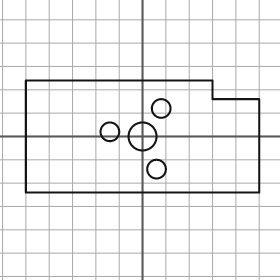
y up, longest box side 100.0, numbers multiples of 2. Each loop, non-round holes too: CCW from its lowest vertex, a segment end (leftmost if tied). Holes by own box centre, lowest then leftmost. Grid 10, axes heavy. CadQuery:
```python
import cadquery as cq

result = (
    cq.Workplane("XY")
    .moveTo(-50.0, -24.0)
    .lineTo(50.0, -24.0)
    .lineTo(50.0, 16.0)
    .lineTo(30.0, 16.0)
    .lineTo(30.0, 24.0)
    .lineTo(-50.0, 24.0)
    .close()
    .moveTo(6.0, -14.0)
    .circle(4.0)
    .moveTo(0.0, 0.0)
    .circle(6.0)
    .moveTo(-14.0, 2.0)
    .circle(4.0)
    .moveTo(8.0, 12.0)
    .circle(4.0)
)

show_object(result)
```